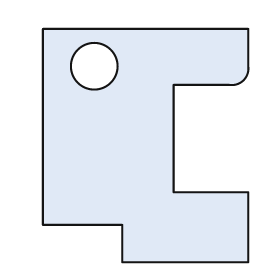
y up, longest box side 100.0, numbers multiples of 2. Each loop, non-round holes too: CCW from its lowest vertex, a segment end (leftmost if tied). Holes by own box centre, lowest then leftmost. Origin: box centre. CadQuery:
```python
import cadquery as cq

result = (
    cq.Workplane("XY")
    .moveTo(-10.0, -50.0)
    .lineTo(44.0, -50.0)
    .lineTo(44.0, -20.0)
    .lineTo(12.0, -20.0)
    .lineTo(12.0, 26.0)
    .lineTo(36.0, 26.0)
    .threePointArc((42.0, 28.0), (44.0, 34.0))
    .lineTo(44.0, 50.0)
    .lineTo(-44.0, 50.0)
    .lineTo(-44.0, -34.0)
    .lineTo(-10.0, -34.0)
    .close()
    .moveTo(-22.0, 34.0)
    .circle(10.0)
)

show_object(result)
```